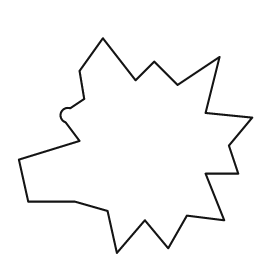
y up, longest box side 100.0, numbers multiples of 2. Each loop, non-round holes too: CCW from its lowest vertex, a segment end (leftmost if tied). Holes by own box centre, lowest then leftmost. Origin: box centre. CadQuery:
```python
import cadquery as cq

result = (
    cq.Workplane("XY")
    .moveTo(-8.0, -46.0)
    .lineTo(4.0, -32.0)
    .lineTo(14.0, -44.0)
    .lineTo(22.0, -30.0)
    .lineTo(38.0, -32.0)
    .lineTo(30.0, -12.0)
    .lineTo(44.0, -12.0)
    .lineTo(40.0, 0.0)
    .lineTo(50.0, 12.0)
    .lineTo(30.0, 14.0)
    .lineTo(36.0, 38.0)
    .lineTo(18.0, 26.0)
    .lineTo(8.0, 36.0)
    .lineTo(0.0, 28.0)
    .lineTo(-14.0, 46.0)
    .lineTo(-24.0, 32.0)
    .lineTo(-22.0, 20.0)
    .lineTo(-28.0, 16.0)
    .threePointArc((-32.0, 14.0), (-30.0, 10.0))
    .lineTo(-24.0, 2.0)
    .lineTo(-50.0, -6.0)
    .lineTo(-46.0, -24.0)
    .lineTo(-26.0, -24.0)
    .lineTo(-12.0, -28.0)
    .close()
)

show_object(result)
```